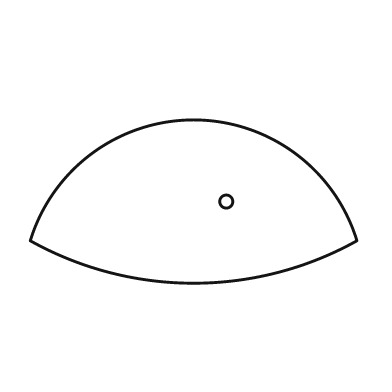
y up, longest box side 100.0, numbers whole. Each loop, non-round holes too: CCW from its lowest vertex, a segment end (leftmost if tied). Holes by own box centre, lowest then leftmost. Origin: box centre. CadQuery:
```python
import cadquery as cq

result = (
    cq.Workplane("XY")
    .moveTo(-50.0, -12.0)
    .threePointArc((0.0, -25.0), (50.0, -12.0))
    .threePointArc((0.0, 25.0), (-50.0, -12.0))
    .close()
    .moveTo(10.0, 0.0)
    .circle(2.0)
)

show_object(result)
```